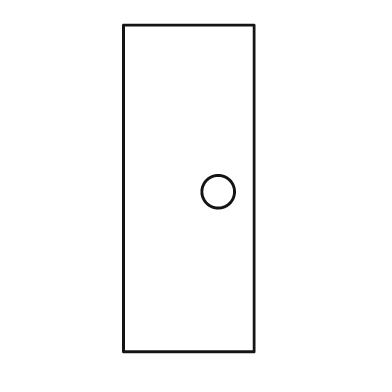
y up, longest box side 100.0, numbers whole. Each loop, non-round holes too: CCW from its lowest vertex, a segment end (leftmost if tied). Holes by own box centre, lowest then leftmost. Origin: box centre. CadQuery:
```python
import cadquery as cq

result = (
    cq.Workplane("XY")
    .moveTo(-20.0, -50.0)
    .lineTo(20.0, -50.0)
    .lineTo(20.0, 50.0)
    .lineTo(-20.0, 50.0)
    .close()
    .moveTo(9.0, -1.0)
    .circle(5.0)
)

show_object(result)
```